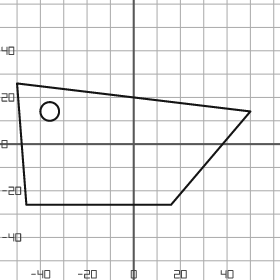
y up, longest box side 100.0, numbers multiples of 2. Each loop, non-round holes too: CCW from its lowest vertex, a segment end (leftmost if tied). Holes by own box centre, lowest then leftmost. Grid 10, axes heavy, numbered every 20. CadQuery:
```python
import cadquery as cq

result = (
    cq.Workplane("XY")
    .moveTo(-46.0, -26.0)
    .lineTo(16.0, -26.0)
    .lineTo(50.0, 14.0)
    .lineTo(-50.0, 26.0)
    .close()
    .moveTo(-36.0, 14.0)
    .circle(4.0)
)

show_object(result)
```